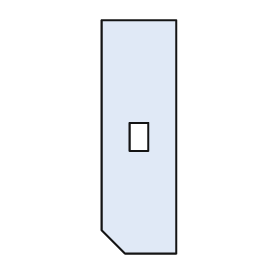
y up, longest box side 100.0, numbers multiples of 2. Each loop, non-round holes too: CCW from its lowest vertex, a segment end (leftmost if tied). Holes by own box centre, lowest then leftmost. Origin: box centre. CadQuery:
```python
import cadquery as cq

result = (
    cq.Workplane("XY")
    .moveTo(-6.0, -50.0)
    .lineTo(16.0, -50.0)
    .lineTo(16.0, 50.0)
    .lineTo(-16.0, 50.0)
    .lineTo(-16.0, -40.0)
    .close()
    .moveTo(-4.0, -6.0)
    .lineTo(4.0, -6.0)
    .lineTo(4.0, 6.0)
    .lineTo(-4.0, 6.0)
    .close()
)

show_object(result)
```